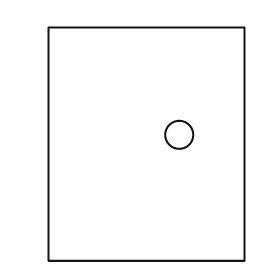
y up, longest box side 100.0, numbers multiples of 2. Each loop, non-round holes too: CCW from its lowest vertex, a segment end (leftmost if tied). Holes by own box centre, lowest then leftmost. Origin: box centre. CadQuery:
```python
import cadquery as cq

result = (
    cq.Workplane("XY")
    .moveTo(-42.0, -50.0)
    .lineTo(42.0, -50.0)
    .lineTo(42.0, 50.0)
    .lineTo(-42.0, 50.0)
    .close()
    .moveTo(14.0, 4.0)
    .circle(6.0)
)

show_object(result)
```